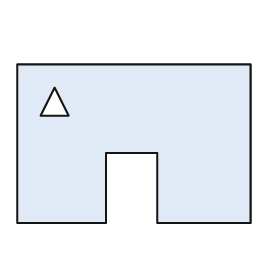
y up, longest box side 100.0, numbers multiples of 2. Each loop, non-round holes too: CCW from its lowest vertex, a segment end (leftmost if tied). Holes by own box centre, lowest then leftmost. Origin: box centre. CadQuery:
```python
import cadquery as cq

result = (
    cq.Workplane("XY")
    .moveTo(-50.0, -34.0)
    .lineTo(-12.0, -34.0)
    .lineTo(-12.0, -4.0)
    .lineTo(10.0, -4.0)
    .lineTo(10.0, -34.0)
    .lineTo(50.0, -34.0)
    .lineTo(50.0, 34.0)
    .lineTo(-50.0, 34.0)
    .close()
    .moveTo(-40.0, 12.0)
    .lineTo(-28.0, 12.0)
    .lineTo(-34.0, 24.0)
    .close()
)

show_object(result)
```